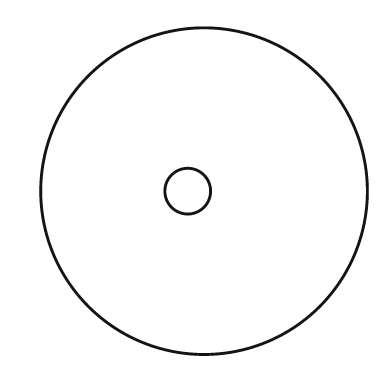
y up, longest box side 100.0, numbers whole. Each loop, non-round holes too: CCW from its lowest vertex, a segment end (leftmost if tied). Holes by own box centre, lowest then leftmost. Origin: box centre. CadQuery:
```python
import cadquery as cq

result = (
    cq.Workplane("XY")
    .moveTo(0.0, 0.0)
    .circle(50.0)
    .moveTo(-5.0, 0.0)
    .circle(7.0)
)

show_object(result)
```